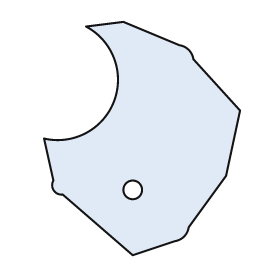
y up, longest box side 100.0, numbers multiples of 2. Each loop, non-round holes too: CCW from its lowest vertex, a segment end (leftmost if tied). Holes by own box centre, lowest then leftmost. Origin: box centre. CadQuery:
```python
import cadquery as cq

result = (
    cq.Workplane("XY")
    .moveTo(-4.0, -50.0)
    .lineTo(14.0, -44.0)
    .threePointArc((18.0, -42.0), (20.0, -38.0))
    .lineTo(36.0, -16.0)
    .lineTo(42.0, 12.0)
    .lineTo(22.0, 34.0)
    .threePointArc((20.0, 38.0), (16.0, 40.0))
    .lineTo(-8.0, 50.0)
    .lineTo(-24.0, 48.0)
    .threePointArc((-12.0, 16.0), (-42.0, 0.0))
    .lineTo(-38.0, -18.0)
    .threePointArc((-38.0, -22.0), (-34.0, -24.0))
    .close()
    .moveTo(-4.0, -22.0)
    .circle(4.0)
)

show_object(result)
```